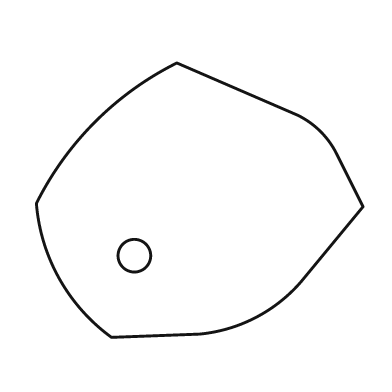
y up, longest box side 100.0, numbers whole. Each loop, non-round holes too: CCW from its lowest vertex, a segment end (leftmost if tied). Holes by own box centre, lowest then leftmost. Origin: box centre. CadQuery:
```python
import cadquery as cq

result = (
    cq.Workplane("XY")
    .moveTo(-27.0, -42.0)
    .lineTo(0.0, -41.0)
    .threePointArc((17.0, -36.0), (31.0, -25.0))
    .lineTo(50.0, -2.0)
    .lineTo(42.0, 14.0)
    .threePointArc((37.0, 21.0), (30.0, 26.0))
    .lineTo(-7.0, 42.0)
    .threePointArc((-32.0, 24.0), (-50.0, -1.0))
    .threePointArc((-43.0, -24.0), (-27.0, -42.0))
    .close()
    .moveTo(-20.0, -17.0)
    .circle(5.0)
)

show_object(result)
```